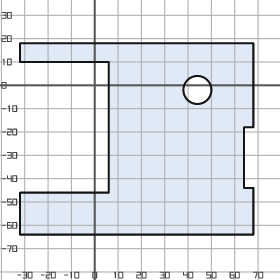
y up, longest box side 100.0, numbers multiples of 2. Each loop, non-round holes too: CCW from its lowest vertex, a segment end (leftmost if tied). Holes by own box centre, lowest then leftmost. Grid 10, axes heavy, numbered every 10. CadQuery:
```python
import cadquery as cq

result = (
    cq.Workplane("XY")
    .moveTo(-32.0, -64.0)
    .lineTo(68.0, -64.0)
    .lineTo(68.0, -44.0)
    .lineTo(64.0, -44.0)
    .lineTo(64.0, -18.0)
    .lineTo(68.0, -18.0)
    .lineTo(68.0, 18.0)
    .lineTo(-32.0, 18.0)
    .lineTo(-32.0, 10.0)
    .lineTo(6.0, 10.0)
    .lineTo(6.0, -46.0)
    .lineTo(-32.0, -46.0)
    .close()
    .moveTo(44.0, -2.0)
    .circle(6.0)
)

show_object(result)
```